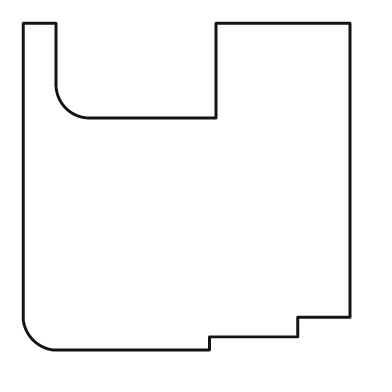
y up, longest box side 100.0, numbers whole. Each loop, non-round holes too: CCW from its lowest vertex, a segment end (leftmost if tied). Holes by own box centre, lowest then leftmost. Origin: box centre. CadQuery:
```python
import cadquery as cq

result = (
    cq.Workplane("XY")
    .moveTo(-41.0, -50.0)
    .lineTo(7.0, -50.0)
    .lineTo(7.0, -46.0)
    .lineTo(34.0, -46.0)
    .lineTo(34.0, -40.0)
    .lineTo(50.0, -40.0)
    .lineTo(50.0, 50.0)
    .lineTo(9.0, 50.0)
    .lineTo(9.0, 21.0)
    .lineTo(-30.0, 21.0)
    .threePointArc((-37.0, 24.0), (-40.0, 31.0))
    .lineTo(-40.0, 50.0)
    .lineTo(-50.0, 50.0)
    .lineTo(-50.0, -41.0)
    .threePointArc((-47.0, -47.0), (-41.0, -50.0))
    .close()
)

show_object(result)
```